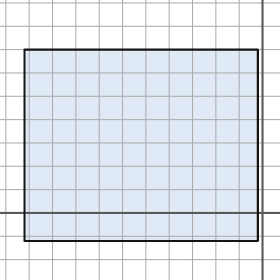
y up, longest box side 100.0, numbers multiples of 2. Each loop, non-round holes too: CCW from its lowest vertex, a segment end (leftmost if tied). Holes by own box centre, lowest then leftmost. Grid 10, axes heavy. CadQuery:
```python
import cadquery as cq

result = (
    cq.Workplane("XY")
    .moveTo(-102.0, -12.0)
    .lineTo(-2.0, -12.0)
    .lineTo(-2.0, 70.0)
    .lineTo(-102.0, 70.0)
    .close()
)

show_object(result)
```